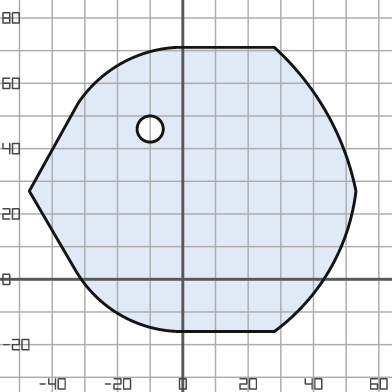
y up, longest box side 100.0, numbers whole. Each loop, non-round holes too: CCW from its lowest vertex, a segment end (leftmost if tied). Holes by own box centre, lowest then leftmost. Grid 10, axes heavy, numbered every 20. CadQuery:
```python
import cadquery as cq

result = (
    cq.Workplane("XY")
    .moveTo(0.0, -16.0)
    .lineTo(28.0, -16.0)
    .threePointArc((45.0, 3.0), (53.0, 27.0))
    .threePointArc((44.0, 51.0), (28.0, 71.0))
    .lineTo(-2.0, 71.0)
    .threePointArc((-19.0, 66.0), (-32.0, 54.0))
    .lineTo(-47.0, 27.0)
    .lineTo(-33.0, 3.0)
    .threePointArc((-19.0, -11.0), (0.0, -16.0))
    .close()
    .moveTo(-10.0, 46.0)
    .circle(4.0)
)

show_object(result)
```